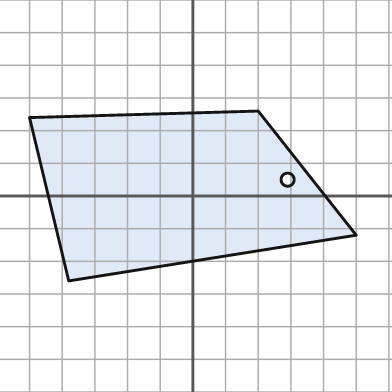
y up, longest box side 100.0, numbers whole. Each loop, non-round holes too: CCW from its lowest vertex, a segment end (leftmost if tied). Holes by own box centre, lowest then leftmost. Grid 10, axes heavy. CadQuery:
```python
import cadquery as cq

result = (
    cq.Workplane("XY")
    .moveTo(-38.0, -26.0)
    .lineTo(50.0, -12.0)
    .lineTo(20.0, 26.0)
    .lineTo(-50.0, 24.0)
    .close()
    .moveTo(29.0, 5.0)
    .circle(2.0)
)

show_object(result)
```